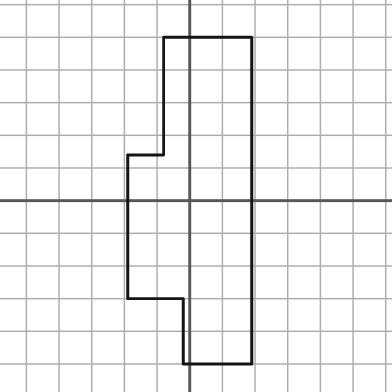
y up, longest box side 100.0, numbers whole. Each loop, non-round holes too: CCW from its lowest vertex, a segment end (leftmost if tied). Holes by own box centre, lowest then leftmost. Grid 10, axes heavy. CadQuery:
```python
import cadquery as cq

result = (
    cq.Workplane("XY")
    .moveTo(-2.0, -50.0)
    .lineTo(19.0, -50.0)
    .lineTo(19.0, 50.0)
    .lineTo(-8.0, 50.0)
    .lineTo(-8.0, 14.0)
    .lineTo(-19.0, 14.0)
    .lineTo(-19.0, -30.0)
    .lineTo(-2.0, -30.0)
    .close()
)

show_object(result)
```